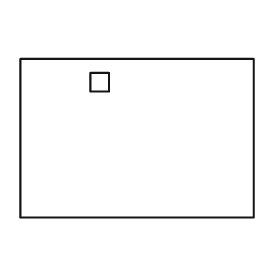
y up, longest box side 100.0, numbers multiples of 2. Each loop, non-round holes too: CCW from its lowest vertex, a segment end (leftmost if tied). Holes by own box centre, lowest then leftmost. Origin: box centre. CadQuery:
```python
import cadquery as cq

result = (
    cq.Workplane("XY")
    .moveTo(-50.0, -34.0)
    .lineTo(50.0, -34.0)
    .lineTo(50.0, 34.0)
    .lineTo(-50.0, 34.0)
    .close()
    .moveTo(-20.0, 20.0)
    .lineTo(-12.0, 20.0)
    .lineTo(-12.0, 28.0)
    .lineTo(-20.0, 28.0)
    .close()
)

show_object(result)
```